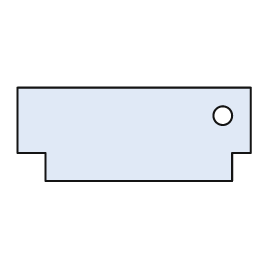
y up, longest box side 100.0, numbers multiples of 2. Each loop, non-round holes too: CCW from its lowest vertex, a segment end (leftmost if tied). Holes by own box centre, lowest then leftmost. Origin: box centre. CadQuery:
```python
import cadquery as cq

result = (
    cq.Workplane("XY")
    .moveTo(-38.0, -20.0)
    .lineTo(42.0, -20.0)
    .lineTo(42.0, -8.0)
    .lineTo(50.0, -8.0)
    .lineTo(50.0, 20.0)
    .lineTo(-50.0, 20.0)
    .lineTo(-50.0, -8.0)
    .lineTo(-38.0, -8.0)
    .close()
    .moveTo(38.0, 8.0)
    .circle(4.0)
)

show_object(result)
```